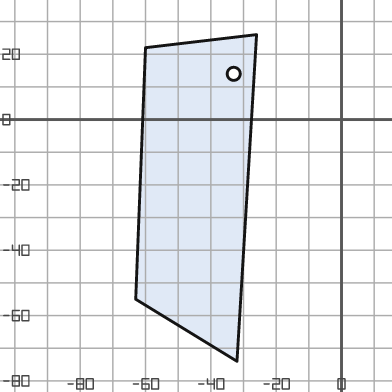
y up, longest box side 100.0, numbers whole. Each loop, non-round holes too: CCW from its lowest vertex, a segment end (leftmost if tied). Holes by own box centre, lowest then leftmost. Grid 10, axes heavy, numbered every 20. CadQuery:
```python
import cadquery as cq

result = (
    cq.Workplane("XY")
    .moveTo(-32.0, -74.0)
    .lineTo(-26.0, 26.0)
    .lineTo(-60.0, 22.0)
    .lineTo(-63.0, -55.0)
    .close()
    .moveTo(-33.0, 14.0)
    .circle(2.0)
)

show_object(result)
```